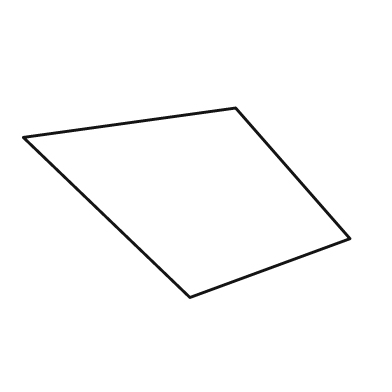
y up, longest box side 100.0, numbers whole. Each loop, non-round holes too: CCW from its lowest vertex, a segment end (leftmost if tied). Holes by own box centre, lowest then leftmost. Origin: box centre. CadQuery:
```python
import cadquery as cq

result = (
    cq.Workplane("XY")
    .moveTo(1.0, -29.0)
    .lineTo(50.0, -11.0)
    .lineTo(15.0, 29.0)
    .lineTo(-50.0, 20.0)
    .close()
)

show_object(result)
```